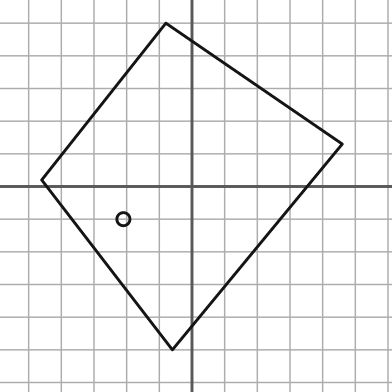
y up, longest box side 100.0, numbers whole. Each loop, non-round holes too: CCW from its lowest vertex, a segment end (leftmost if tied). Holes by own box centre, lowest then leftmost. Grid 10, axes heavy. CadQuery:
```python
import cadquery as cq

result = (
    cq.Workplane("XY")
    .moveTo(-6.0, -50.0)
    .lineTo(46.0, 13.0)
    .lineTo(-8.0, 50.0)
    .lineTo(-46.0, 2.0)
    .close()
    .moveTo(-21.0, -10.0)
    .circle(2.0)
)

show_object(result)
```